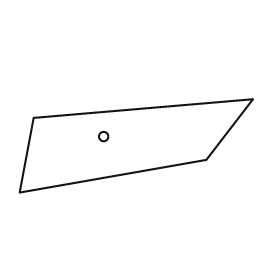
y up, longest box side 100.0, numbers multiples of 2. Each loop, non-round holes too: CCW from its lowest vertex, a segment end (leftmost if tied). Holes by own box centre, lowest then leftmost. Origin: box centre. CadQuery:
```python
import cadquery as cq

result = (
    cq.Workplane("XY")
    .moveTo(-50.0, -20.0)
    .lineTo(30.0, -6.0)
    .lineTo(50.0, 20.0)
    .lineTo(-44.0, 12.0)
    .close()
    .moveTo(-14.0, 4.0)
    .circle(2.0)
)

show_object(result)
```